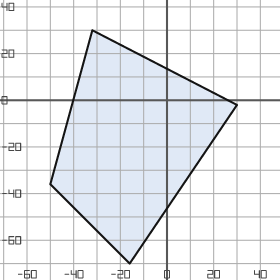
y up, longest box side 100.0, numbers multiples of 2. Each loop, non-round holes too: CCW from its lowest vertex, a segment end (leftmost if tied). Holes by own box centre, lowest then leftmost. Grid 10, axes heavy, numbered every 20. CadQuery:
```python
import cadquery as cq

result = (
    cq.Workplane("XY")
    .moveTo(-16.0, -70.0)
    .lineTo(30.0, -2.0)
    .lineTo(-32.0, 30.0)
    .lineTo(-50.0, -36.0)
    .close()
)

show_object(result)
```